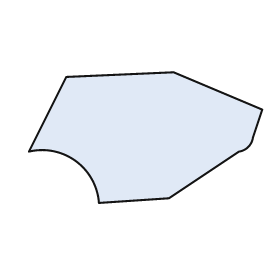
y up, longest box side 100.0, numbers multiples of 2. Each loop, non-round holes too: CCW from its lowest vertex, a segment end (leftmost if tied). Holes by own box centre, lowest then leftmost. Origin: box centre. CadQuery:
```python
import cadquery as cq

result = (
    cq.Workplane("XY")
    .moveTo(-20.0, -28.0)
    .lineTo(10.0, -26.0)
    .lineTo(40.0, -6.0)
    .threePointArc((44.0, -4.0), (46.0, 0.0))
    .lineTo(50.0, 12.0)
    .lineTo(12.0, 28.0)
    .lineTo(-34.0, 26.0)
    .lineTo(-50.0, -6.0)
    .threePointArc((-30.0, -10.0), (-20.0, -28.0))
    .close()
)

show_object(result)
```